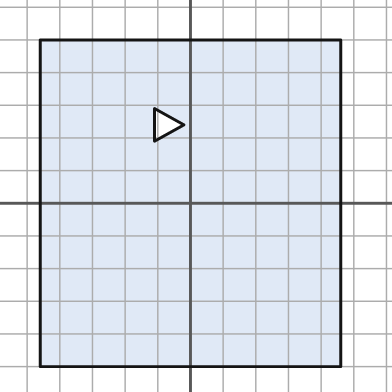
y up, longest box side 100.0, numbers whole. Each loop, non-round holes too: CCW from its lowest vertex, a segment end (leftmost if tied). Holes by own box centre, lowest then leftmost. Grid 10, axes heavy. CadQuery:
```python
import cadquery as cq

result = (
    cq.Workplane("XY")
    .moveTo(-46.0, -50.0)
    .lineTo(46.0, -50.0)
    .lineTo(46.0, 50.0)
    .lineTo(-46.0, 50.0)
    .close()
    .moveTo(-11.0, 19.0)
    .lineTo(-2.0, 24.0)
    .lineTo(-11.0, 29.0)
    .close()
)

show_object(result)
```